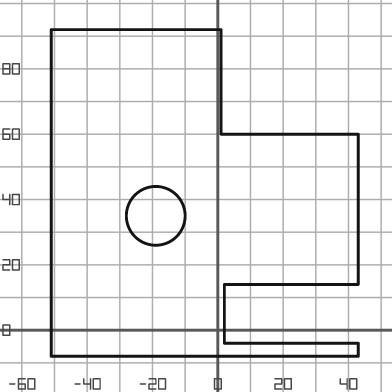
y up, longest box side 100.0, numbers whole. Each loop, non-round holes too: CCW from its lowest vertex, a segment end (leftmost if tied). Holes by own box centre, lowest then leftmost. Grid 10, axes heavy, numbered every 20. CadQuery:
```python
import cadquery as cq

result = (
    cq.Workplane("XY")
    .moveTo(-51.0, -8.0)
    .lineTo(43.0, -8.0)
    .lineTo(43.0, -4.0)
    .lineTo(2.0, -4.0)
    .lineTo(2.0, 14.0)
    .lineTo(43.0, 14.0)
    .lineTo(43.0, 60.0)
    .lineTo(1.0, 60.0)
    .lineTo(1.0, 92.0)
    .lineTo(-51.0, 92.0)
    .close()
    .moveTo(-19.0, 35.0)
    .circle(9.0)
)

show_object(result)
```